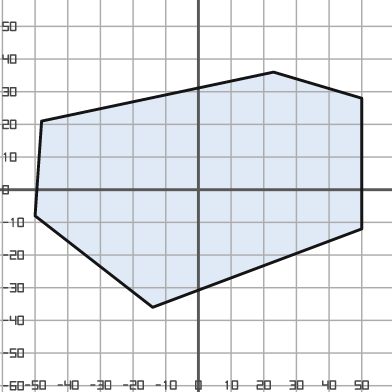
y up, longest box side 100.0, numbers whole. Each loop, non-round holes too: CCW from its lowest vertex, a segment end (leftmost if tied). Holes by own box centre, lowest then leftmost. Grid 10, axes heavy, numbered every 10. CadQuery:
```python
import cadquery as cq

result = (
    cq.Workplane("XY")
    .moveTo(-14.0, -36.0)
    .lineTo(50.0, -12.0)
    .lineTo(50.0, 28.0)
    .lineTo(23.0, 36.0)
    .lineTo(-48.0, 21.0)
    .lineTo(-50.0, -8.0)
    .close()
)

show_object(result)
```